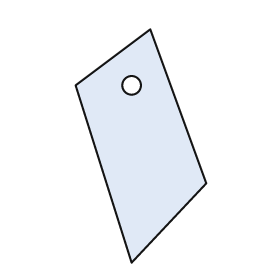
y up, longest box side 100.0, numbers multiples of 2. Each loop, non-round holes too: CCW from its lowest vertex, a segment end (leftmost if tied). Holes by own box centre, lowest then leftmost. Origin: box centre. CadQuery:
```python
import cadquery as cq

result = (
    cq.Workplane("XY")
    .moveTo(-4.0, -50.0)
    .lineTo(28.0, -16.0)
    .lineTo(4.0, 50.0)
    .lineTo(-28.0, 26.0)
    .close()
    .moveTo(-4.0, 26.0)
    .circle(4.0)
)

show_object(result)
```